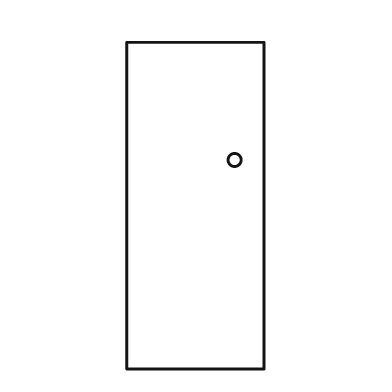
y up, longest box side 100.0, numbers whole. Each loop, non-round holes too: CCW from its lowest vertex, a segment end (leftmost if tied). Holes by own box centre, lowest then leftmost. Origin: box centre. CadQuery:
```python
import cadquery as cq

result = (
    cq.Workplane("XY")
    .moveTo(-21.0, -50.0)
    .lineTo(21.0, -50.0)
    .lineTo(21.0, 50.0)
    .lineTo(-21.0, 50.0)
    .close()
    .moveTo(12.0, 14.0)
    .circle(2.0)
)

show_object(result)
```